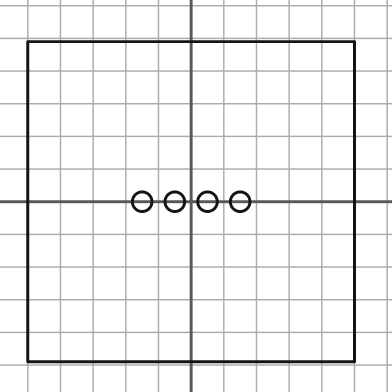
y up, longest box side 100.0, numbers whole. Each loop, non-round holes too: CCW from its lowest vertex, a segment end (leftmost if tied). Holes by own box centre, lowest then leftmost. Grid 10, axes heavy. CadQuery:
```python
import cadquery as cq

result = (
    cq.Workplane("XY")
    .moveTo(-50.0, -49.0)
    .lineTo(50.0, -49.0)
    .lineTo(50.0, 49.0)
    .lineTo(-50.0, 49.0)
    .close()
    .moveTo(-15.0, 0.0)
    .circle(3.0)
    .moveTo(-5.0, 0.0)
    .circle(3.0)
    .moveTo(5.0, 0.0)
    .circle(3.0)
    .moveTo(15.0, 0.0)
    .circle(3.0)
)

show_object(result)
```